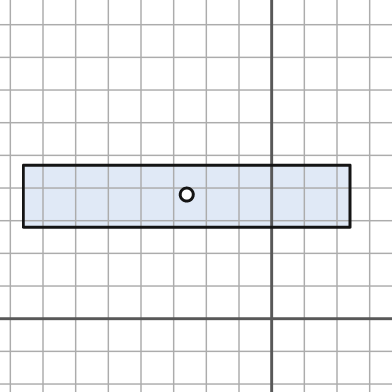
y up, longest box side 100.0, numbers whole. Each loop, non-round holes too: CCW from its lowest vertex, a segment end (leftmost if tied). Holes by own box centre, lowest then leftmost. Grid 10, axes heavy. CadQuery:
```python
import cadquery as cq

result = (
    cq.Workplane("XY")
    .moveTo(-76.0, 28.0)
    .lineTo(24.0, 28.0)
    .lineTo(24.0, 47.0)
    .lineTo(-76.0, 47.0)
    .close()
    .moveTo(-26.0, 38.0)
    .circle(2.0)
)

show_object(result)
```